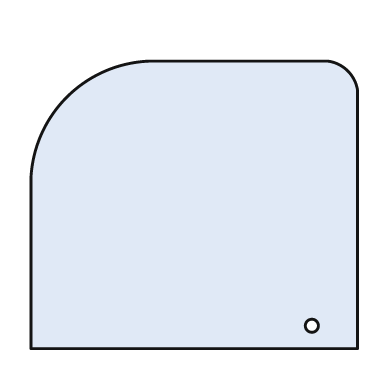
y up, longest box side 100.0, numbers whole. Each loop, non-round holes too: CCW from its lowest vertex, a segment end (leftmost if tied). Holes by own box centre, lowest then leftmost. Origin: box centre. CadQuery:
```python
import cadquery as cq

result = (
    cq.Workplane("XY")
    .moveTo(-50.0, -44.0)
    .lineTo(50.0, -44.0)
    .lineTo(50.0, 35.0)
    .threePointArc((47.0, 41.0), (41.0, 44.0))
    .lineTo(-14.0, 44.0)
    .threePointArc((-39.0, 33.0), (-50.0, 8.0))
    .close()
    .moveTo(36.0, -37.0)
    .circle(2.0)
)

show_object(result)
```